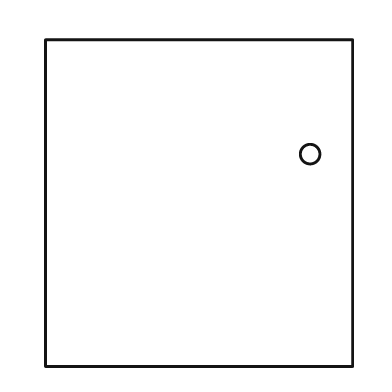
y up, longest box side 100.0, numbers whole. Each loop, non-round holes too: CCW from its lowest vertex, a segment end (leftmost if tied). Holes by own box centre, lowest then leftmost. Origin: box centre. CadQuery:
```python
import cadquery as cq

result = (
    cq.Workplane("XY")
    .moveTo(-47.0, -50.0)
    .lineTo(47.0, -50.0)
    .lineTo(47.0, 50.0)
    .lineTo(-47.0, 50.0)
    .close()
    .moveTo(34.0, 15.0)
    .circle(3.0)
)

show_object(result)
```